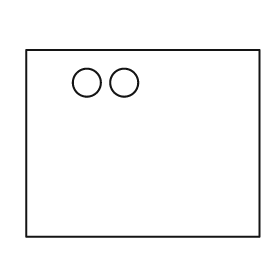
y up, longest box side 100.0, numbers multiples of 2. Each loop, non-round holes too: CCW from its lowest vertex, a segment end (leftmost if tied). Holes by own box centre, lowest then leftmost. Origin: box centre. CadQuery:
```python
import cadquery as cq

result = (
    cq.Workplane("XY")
    .moveTo(-50.0, -40.0)
    .lineTo(50.0, -40.0)
    .lineTo(50.0, 40.0)
    .lineTo(-50.0, 40.0)
    .close()
    .moveTo(-24.0, 26.0)
    .circle(6.0)
    .moveTo(-8.0, 26.0)
    .circle(6.0)
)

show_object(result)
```